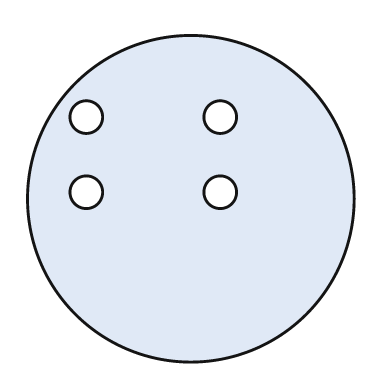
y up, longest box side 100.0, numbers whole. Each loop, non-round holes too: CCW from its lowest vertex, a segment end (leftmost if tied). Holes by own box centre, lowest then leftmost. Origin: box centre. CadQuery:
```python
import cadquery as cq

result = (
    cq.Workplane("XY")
    .moveTo(0.0, 0.0)
    .circle(50.0)
    .moveTo(-32.0, 2.0)
    .circle(5.0)
    .moveTo(9.0, 2.0)
    .circle(5.0)
    .moveTo(-32.0, 25.0)
    .circle(5.0)
    .moveTo(9.0, 25.0)
    .circle(5.0)
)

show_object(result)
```